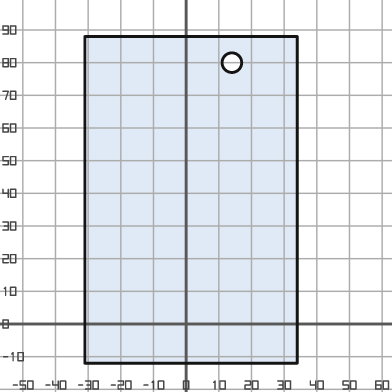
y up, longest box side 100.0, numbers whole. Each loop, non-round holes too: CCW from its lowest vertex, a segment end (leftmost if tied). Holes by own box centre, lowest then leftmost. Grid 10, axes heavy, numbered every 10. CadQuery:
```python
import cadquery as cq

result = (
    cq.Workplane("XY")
    .moveTo(-31.0, -12.0)
    .lineTo(34.0, -12.0)
    .lineTo(34.0, 88.0)
    .lineTo(-31.0, 88.0)
    .close()
    .moveTo(14.0, 80.0)
    .circle(3.0)
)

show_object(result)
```